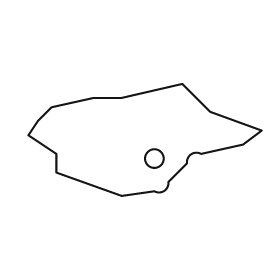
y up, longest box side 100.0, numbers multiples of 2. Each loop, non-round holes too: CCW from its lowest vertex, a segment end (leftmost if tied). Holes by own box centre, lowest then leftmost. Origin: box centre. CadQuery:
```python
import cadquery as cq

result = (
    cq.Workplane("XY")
    .moveTo(-10.0, -24.0)
    .lineTo(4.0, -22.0)
    .threePointArc((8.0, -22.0), (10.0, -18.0))
    .lineTo(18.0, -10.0)
    .threePointArc((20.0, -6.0), (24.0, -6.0))
    .lineTo(42.0, -2.0)
    .lineTo(50.0, 4.0)
    .lineTo(28.0, 12.0)
    .lineTo(16.0, 24.0)
    .lineTo(-10.0, 18.0)
    .lineTo(-22.0, 18.0)
    .lineTo(-40.0, 14.0)
    .lineTo(-46.0, 8.0)
    .lineTo(-50.0, 2.0)
    .lineTo(-38.0, -6.0)
    .lineTo(-38.0, -14.0)
    .close()
    .moveTo(4.0, -8.0)
    .circle(4.0)
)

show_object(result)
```